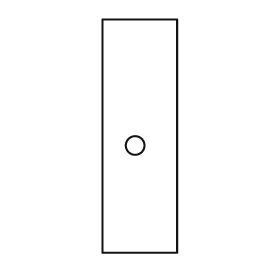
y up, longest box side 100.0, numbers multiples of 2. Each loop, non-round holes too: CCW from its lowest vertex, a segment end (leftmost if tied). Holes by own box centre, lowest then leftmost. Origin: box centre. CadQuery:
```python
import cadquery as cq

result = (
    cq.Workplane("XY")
    .moveTo(-16.0, -50.0)
    .lineTo(16.0, -50.0)
    .lineTo(16.0, 50.0)
    .lineTo(-16.0, 50.0)
    .close()
    .moveTo(-2.0, -4.0)
    .circle(4.0)
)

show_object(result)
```